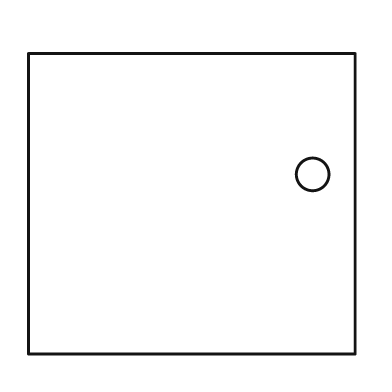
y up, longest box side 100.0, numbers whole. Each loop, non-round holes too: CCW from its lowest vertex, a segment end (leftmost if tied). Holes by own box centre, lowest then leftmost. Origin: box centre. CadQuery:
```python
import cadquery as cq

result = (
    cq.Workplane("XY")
    .moveTo(-50.0, -46.0)
    .lineTo(50.0, -46.0)
    .lineTo(50.0, 46.0)
    .lineTo(-50.0, 46.0)
    .close()
    .moveTo(37.0, 9.0)
    .circle(5.0)
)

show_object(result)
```